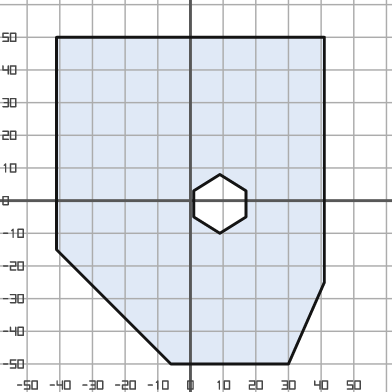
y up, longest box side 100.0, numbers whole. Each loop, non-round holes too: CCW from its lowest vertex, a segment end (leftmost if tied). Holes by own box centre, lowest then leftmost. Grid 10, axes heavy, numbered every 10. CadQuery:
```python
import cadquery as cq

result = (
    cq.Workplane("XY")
    .moveTo(-6.0, -50.0)
    .lineTo(30.0, -50.0)
    .lineTo(41.0, -25.0)
    .lineTo(41.0, 50.0)
    .lineTo(-41.0, 50.0)
    .lineTo(-41.0, -15.0)
    .close()
    .moveTo(9.0, -10.0)
    .lineTo(17.0, -5.0)
    .lineTo(17.0, 3.0)
    .lineTo(9.0, 8.0)
    .lineTo(1.0, 3.0)
    .lineTo(1.0, -5.0)
    .close()
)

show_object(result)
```